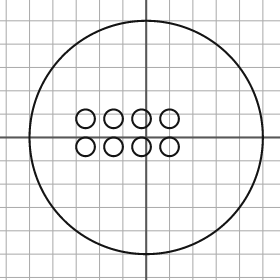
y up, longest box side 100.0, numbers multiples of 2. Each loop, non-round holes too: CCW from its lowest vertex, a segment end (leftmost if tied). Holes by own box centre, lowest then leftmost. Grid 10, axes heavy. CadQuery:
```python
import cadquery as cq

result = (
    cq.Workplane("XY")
    .moveTo(0.0, 0.0)
    .circle(50.0)
    .moveTo(-26.0, -4.0)
    .circle(4.0)
    .moveTo(-14.0, -4.0)
    .circle(4.0)
    .moveTo(-2.0, -4.0)
    .circle(4.0)
    .moveTo(10.0, -4.0)
    .circle(4.0)
    .moveTo(-26.0, 8.0)
    .circle(4.0)
    .moveTo(-14.0, 8.0)
    .circle(4.0)
    .moveTo(-2.0, 8.0)
    .circle(4.0)
    .moveTo(10.0, 8.0)
    .circle(4.0)
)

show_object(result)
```